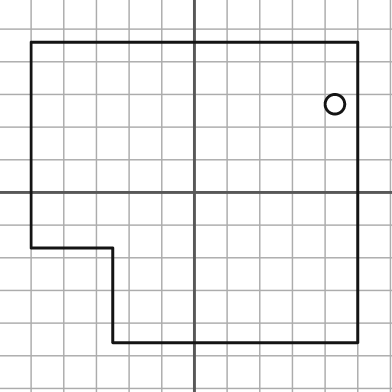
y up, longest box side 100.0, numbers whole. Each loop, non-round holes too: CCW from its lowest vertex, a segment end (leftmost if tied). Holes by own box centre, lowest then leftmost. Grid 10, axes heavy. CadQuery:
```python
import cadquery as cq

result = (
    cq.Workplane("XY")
    .moveTo(-25.0, -46.0)
    .lineTo(50.0, -46.0)
    .lineTo(50.0, 46.0)
    .lineTo(-50.0, 46.0)
    .lineTo(-50.0, -17.0)
    .lineTo(-25.0, -17.0)
    .close()
    .moveTo(43.0, 27.0)
    .circle(3.0)
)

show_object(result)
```